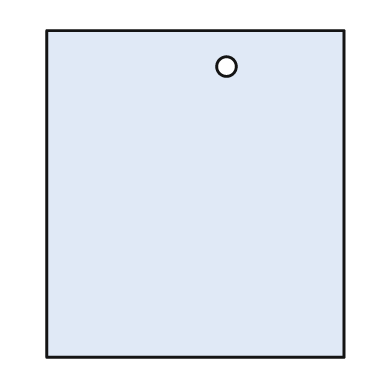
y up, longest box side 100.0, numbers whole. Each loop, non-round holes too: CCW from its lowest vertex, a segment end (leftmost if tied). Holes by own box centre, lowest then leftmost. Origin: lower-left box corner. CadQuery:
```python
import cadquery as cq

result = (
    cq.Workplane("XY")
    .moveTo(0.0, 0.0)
    .lineTo(91.0, 0.0)
    .lineTo(91.0, 100.0)
    .lineTo(0.0, 100.0)
    .close()
    .moveTo(55.0, 89.0)
    .circle(3.0)
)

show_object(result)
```